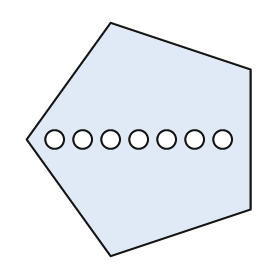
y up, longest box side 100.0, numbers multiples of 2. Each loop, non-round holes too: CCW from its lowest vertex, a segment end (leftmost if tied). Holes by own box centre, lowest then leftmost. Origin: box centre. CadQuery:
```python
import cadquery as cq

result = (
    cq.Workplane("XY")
    .moveTo(-12.0, -50.0)
    .lineTo(48.0, -30.0)
    .lineTo(48.0, 30.0)
    .lineTo(-12.0, 50.0)
    .lineTo(-48.0, 0.0)
    .close()
    .moveTo(-36.0, 0.0)
    .circle(4.0)
    .moveTo(-24.0, 0.0)
    .circle(4.0)
    .moveTo(-12.0, 0.0)
    .circle(4.0)
    .moveTo(0.0, 0.0)
    .circle(4.0)
    .moveTo(12.0, 0.0)
    .circle(4.0)
    .moveTo(24.0, 0.0)
    .circle(4.0)
    .moveTo(36.0, 0.0)
    .circle(4.0)
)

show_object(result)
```